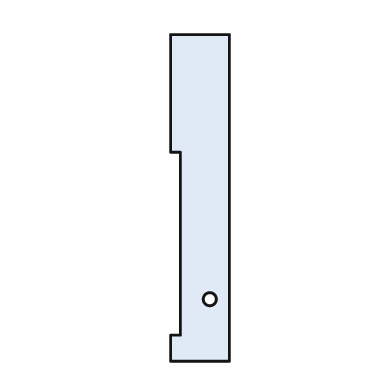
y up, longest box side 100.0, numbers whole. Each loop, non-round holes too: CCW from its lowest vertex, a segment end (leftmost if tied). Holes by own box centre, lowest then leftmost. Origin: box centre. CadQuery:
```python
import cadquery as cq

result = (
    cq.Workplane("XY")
    .moveTo(-9.0, -50.0)
    .lineTo(9.0, -50.0)
    .lineTo(9.0, 50.0)
    .lineTo(-9.0, 50.0)
    .lineTo(-9.0, 14.0)
    .lineTo(-6.0, 14.0)
    .lineTo(-6.0, -42.0)
    .lineTo(-9.0, -42.0)
    .close()
    .moveTo(3.0, -31.0)
    .circle(2.0)
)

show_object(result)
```